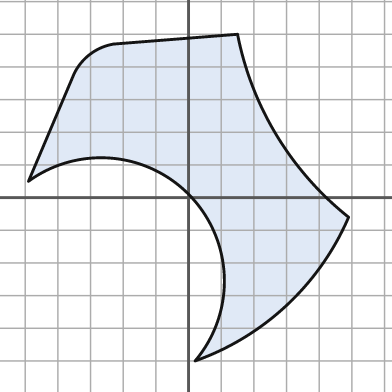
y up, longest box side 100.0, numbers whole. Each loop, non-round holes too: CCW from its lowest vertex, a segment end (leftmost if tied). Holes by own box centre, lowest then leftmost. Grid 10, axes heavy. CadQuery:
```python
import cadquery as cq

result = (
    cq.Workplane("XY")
    .moveTo(2.0, -50.0)
    .threePointArc((30.0, -33.0), (49.0, -6.0))
    .threePointArc((27.0, 19.0), (15.0, 50.0))
    .lineTo(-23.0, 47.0)
    .threePointArc((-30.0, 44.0), (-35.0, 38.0))
    .lineTo(-49.0, 5.0)
    .threePointArc((1.0, 0.0), (2.0, -50.0))
    .close()
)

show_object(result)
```